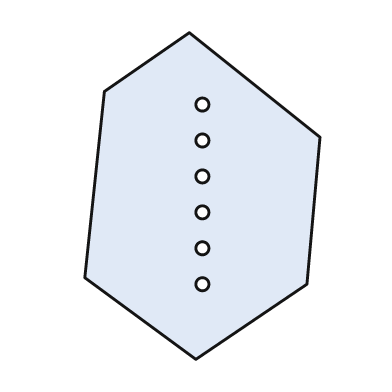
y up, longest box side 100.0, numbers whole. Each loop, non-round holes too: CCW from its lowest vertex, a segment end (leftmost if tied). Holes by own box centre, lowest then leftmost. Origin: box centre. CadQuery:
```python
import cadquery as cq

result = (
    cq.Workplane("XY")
    .moveTo(-2.0, -50.0)
    .lineTo(32.0, -27.0)
    .lineTo(36.0, 18.0)
    .lineTo(-4.0, 50.0)
    .lineTo(-30.0, 32.0)
    .lineTo(-36.0, -25.0)
    .close()
    .moveTo(0.0, -27.0)
    .circle(2.0)
    .moveTo(0.0, -16.0)
    .circle(2.0)
    .moveTo(0.0, -5.0)
    .circle(2.0)
    .moveTo(0.0, 6.0)
    .circle(2.0)
    .moveTo(0.0, 17.0)
    .circle(2.0)
    .moveTo(0.0, 28.0)
    .circle(2.0)
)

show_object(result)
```